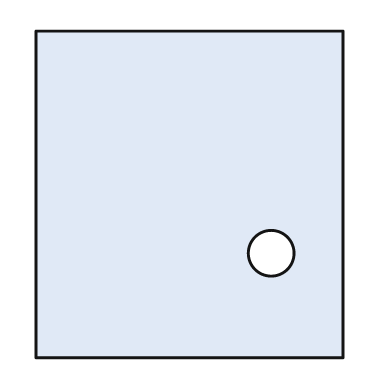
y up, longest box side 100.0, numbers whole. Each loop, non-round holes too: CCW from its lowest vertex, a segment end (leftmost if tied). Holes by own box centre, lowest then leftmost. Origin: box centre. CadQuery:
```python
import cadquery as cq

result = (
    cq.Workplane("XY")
    .moveTo(-47.0, -50.0)
    .lineTo(47.0, -50.0)
    .lineTo(47.0, 50.0)
    .lineTo(-47.0, 50.0)
    .close()
    .moveTo(25.0, -18.0)
    .circle(7.0)
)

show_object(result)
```